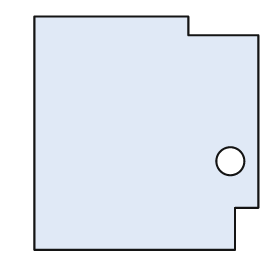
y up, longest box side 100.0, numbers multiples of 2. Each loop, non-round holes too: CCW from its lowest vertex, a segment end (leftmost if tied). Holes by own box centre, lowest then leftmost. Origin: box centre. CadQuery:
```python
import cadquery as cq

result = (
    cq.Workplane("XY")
    .moveTo(-48.0, -50.0)
    .lineTo(38.0, -50.0)
    .lineTo(38.0, -32.0)
    .lineTo(48.0, -32.0)
    .lineTo(48.0, 42.0)
    .lineTo(18.0, 42.0)
    .lineTo(18.0, 50.0)
    .lineTo(-48.0, 50.0)
    .close()
    .moveTo(36.0, -12.0)
    .circle(6.0)
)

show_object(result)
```